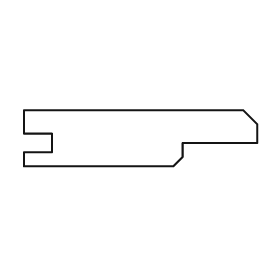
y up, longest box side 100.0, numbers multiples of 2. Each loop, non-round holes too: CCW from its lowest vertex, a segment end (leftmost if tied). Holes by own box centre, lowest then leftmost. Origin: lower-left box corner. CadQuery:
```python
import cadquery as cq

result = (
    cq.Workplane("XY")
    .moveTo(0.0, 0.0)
    .lineTo(64.0, 0.0)
    .lineTo(68.0, 4.0)
    .lineTo(68.0, 10.0)
    .lineTo(100.0, 10.0)
    .lineTo(100.0, 18.0)
    .lineTo(94.0, 24.0)
    .lineTo(0.0, 24.0)
    .lineTo(0.0, 14.0)
    .lineTo(12.0, 14.0)
    .lineTo(12.0, 6.0)
    .lineTo(0.0, 6.0)
    .close()
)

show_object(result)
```